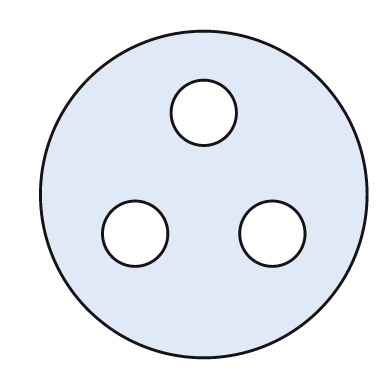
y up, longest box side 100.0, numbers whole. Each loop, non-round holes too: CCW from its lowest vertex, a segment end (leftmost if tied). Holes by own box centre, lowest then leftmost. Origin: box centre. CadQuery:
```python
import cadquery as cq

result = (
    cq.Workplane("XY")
    .moveTo(0.0, 0.0)
    .circle(50.0)
    .moveTo(-21.0, -12.0)
    .circle(10.0)
    .moveTo(21.0, -12.0)
    .circle(10.0)
    .moveTo(0.0, 25.0)
    .circle(10.0)
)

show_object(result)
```